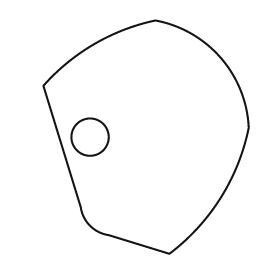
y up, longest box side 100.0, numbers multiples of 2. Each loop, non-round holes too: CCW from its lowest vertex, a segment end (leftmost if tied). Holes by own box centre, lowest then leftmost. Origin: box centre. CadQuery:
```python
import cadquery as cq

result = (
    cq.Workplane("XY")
    .moveTo(10.0, -50.0)
    .threePointArc((32.0, -26.0), (44.0, 4.0))
    .threePointArc((32.0, 34.0), (4.0, 50.0))
    .threePointArc((-22.0, 40.0), (-44.0, 22.0))
    .lineTo(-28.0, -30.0)
    .threePointArc((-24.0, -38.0), (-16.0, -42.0))
    .close()
    .moveTo(-24.0, 0.0)
    .circle(8.0)
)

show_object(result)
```